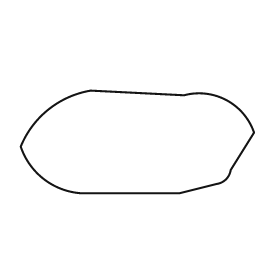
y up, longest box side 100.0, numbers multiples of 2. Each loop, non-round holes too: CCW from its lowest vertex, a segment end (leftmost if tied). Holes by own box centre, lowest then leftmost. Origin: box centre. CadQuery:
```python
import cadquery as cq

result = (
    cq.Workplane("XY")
    .moveTo(-24.0, -22.0)
    .lineTo(18.0, -22.0)
    .lineTo(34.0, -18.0)
    .threePointArc((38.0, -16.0), (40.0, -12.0))
    .lineTo(50.0, 4.0)
    .threePointArc((38.0, 18.0), (20.0, 20.0))
    .lineTo(-20.0, 22.0)
    .threePointArc((-38.0, 14.0), (-50.0, -2.0))
    .threePointArc((-40.0, -16.0), (-24.0, -22.0))
    .close()
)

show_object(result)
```